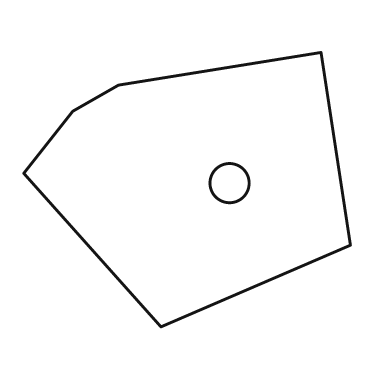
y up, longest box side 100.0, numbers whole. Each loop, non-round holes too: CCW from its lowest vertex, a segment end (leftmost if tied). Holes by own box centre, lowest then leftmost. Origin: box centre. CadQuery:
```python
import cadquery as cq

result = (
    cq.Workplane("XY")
    .moveTo(-8.0, -42.0)
    .lineTo(50.0, -17.0)
    .lineTo(41.0, 42.0)
    .lineTo(-21.0, 32.0)
    .lineTo(-35.0, 24.0)
    .lineTo(-50.0, 5.0)
    .close()
    .moveTo(13.0, 2.0)
    .circle(6.0)
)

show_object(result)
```